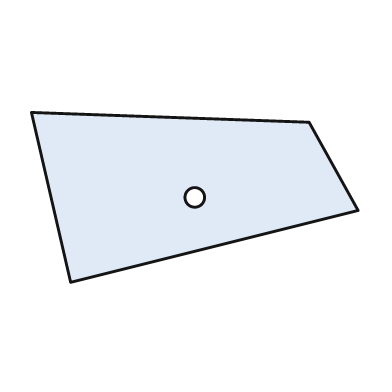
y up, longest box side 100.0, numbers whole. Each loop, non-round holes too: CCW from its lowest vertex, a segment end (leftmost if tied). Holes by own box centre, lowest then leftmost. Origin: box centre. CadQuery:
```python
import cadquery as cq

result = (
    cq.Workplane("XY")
    .moveTo(-38.0, -26.0)
    .lineTo(50.0, -4.0)
    .lineTo(35.0, 23.0)
    .lineTo(-50.0, 26.0)
    .close()
    .moveTo(0.0, 0.0)
    .circle(3.0)
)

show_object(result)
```